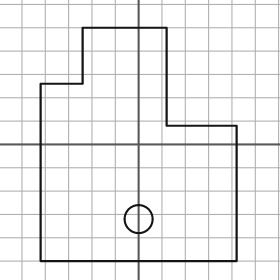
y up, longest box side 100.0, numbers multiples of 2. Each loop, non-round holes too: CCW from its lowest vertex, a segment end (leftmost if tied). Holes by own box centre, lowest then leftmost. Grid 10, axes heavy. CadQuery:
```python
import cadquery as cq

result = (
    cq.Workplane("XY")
    .moveTo(-42.0, -50.0)
    .lineTo(42.0, -50.0)
    .lineTo(42.0, 8.0)
    .lineTo(12.0, 8.0)
    .lineTo(12.0, 50.0)
    .lineTo(-24.0, 50.0)
    .lineTo(-24.0, 26.0)
    .lineTo(-42.0, 26.0)
    .close()
    .moveTo(0.0, -32.0)
    .circle(6.0)
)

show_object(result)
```